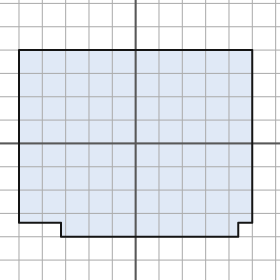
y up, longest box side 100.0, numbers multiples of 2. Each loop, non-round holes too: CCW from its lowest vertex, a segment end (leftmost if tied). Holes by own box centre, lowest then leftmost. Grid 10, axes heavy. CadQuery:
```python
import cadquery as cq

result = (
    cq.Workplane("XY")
    .moveTo(-32.0, -40.0)
    .lineTo(44.0, -40.0)
    .lineTo(44.0, -34.0)
    .lineTo(50.0, -34.0)
    .lineTo(50.0, 40.0)
    .lineTo(-50.0, 40.0)
    .lineTo(-50.0, -34.0)
    .lineTo(-32.0, -34.0)
    .close()
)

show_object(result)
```